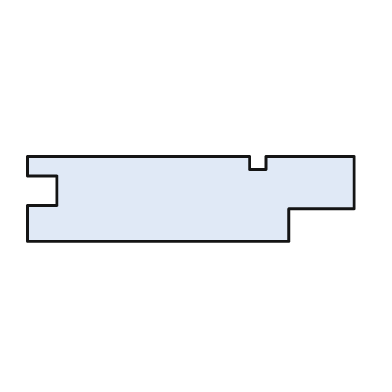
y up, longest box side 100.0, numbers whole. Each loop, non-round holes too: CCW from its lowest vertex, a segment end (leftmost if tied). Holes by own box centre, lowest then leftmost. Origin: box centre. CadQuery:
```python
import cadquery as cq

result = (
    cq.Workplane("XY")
    .moveTo(-50.0, -13.0)
    .lineTo(30.0, -13.0)
    .lineTo(30.0, -3.0)
    .lineTo(50.0, -3.0)
    .lineTo(50.0, 13.0)
    .lineTo(23.0, 13.0)
    .lineTo(23.0, 9.0)
    .lineTo(18.0, 9.0)
    .lineTo(18.0, 13.0)
    .lineTo(-50.0, 13.0)
    .lineTo(-50.0, 7.0)
    .lineTo(-41.0, 7.0)
    .lineTo(-41.0, -2.0)
    .lineTo(-50.0, -2.0)
    .close()
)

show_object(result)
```